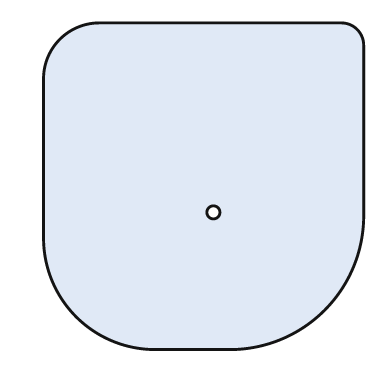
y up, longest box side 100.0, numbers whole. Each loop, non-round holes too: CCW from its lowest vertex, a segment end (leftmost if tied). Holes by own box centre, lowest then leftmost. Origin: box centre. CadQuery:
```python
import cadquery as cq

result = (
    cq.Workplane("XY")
    .moveTo(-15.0, -50.0)
    .lineTo(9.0, -50.0)
    .threePointArc((37.0, -38.0), (49.0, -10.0))
    .lineTo(49.0, 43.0)
    .threePointArc((47.0, 48.0), (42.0, 50.0))
    .lineTo(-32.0, 50.0)
    .threePointArc((-44.0, 45.0), (-49.0, 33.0))
    .lineTo(-49.0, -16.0)
    .threePointArc((-39.0, -40.0), (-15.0, -50.0))
    .close()
    .moveTo(3.0, -8.0)
    .circle(2.0)
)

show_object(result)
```